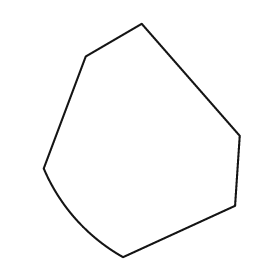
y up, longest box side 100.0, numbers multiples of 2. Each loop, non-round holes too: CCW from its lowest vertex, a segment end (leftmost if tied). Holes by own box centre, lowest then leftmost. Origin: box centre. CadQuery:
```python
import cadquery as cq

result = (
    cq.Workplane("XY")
    .moveTo(-8.0, -50.0)
    .lineTo(40.0, -28.0)
    .lineTo(42.0, 2.0)
    .lineTo(0.0, 50.0)
    .lineTo(-24.0, 36.0)
    .lineTo(-42.0, -12.0)
    .threePointArc((-28.0, -34.0), (-8.0, -50.0))
    .close()
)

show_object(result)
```